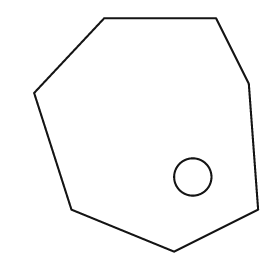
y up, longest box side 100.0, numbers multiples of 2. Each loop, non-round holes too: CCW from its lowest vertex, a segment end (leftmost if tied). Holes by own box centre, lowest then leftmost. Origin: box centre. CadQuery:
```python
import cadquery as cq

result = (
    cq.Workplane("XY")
    .moveTo(12.0, -50.0)
    .lineTo(48.0, -32.0)
    .lineTo(44.0, 22.0)
    .lineTo(30.0, 50.0)
    .lineTo(-18.0, 50.0)
    .lineTo(-48.0, 18.0)
    .lineTo(-32.0, -32.0)
    .close()
    .moveTo(20.0, -18.0)
    .circle(8.0)
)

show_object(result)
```